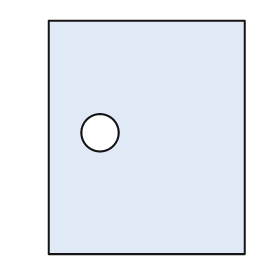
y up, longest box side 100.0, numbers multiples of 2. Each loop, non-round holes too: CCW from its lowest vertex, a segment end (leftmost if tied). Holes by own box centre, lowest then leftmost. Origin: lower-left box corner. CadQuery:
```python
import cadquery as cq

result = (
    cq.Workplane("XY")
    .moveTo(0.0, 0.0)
    .lineTo(84.0, 0.0)
    .lineTo(84.0, 100.0)
    .lineTo(0.0, 100.0)
    .close()
    .moveTo(22.0, 52.0)
    .circle(8.0)
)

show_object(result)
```